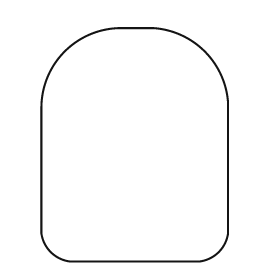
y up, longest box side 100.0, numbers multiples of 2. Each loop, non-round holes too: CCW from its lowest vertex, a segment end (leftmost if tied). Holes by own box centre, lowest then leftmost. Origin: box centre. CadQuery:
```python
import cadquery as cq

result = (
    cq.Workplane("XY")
    .moveTo(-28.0, -50.0)
    .lineTo(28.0, -50.0)
    .threePointArc((36.0, -46.0), (40.0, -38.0))
    .lineTo(40.0, 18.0)
    .threePointArc((30.0, 40.0), (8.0, 50.0))
    .lineTo(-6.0, 50.0)
    .threePointArc((-30.0, 40.0), (-40.0, 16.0))
    .lineTo(-40.0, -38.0)
    .threePointArc((-36.0, -46.0), (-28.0, -50.0))
    .close()
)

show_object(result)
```